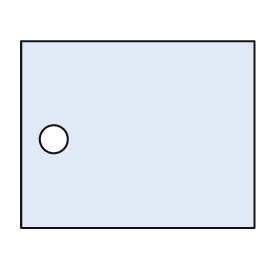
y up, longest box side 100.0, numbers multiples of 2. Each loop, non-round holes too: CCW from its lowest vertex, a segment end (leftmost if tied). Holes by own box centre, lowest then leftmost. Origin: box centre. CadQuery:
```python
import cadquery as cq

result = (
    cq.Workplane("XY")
    .moveTo(-50.0, -40.0)
    .lineTo(50.0, -40.0)
    .lineTo(50.0, 40.0)
    .lineTo(-50.0, 40.0)
    .close()
    .moveTo(-36.0, -2.0)
    .circle(6.0)
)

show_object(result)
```